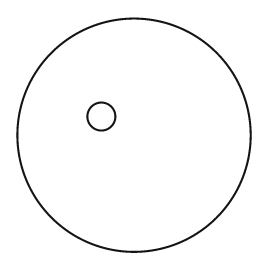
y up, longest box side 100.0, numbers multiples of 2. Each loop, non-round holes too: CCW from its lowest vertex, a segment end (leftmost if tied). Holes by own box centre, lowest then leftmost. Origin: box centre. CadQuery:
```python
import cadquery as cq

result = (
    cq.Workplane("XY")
    .moveTo(0.0, 0.0)
    .circle(50.0)
    .moveTo(-14.0, 8.0)
    .circle(6.0)
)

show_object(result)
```